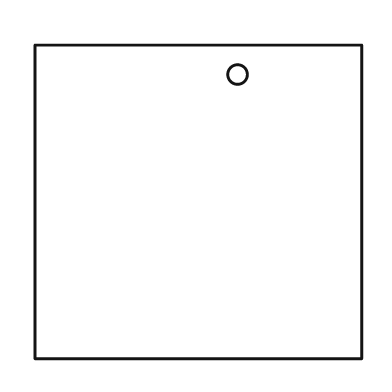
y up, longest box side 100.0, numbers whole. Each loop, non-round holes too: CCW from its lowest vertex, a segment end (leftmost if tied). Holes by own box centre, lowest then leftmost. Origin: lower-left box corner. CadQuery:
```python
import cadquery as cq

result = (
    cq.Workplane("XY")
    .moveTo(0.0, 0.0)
    .lineTo(100.0, 0.0)
    .lineTo(100.0, 96.0)
    .lineTo(0.0, 96.0)
    .close()
    .moveTo(62.0, 87.0)
    .circle(3.0)
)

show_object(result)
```